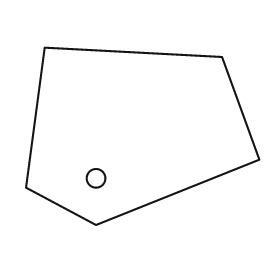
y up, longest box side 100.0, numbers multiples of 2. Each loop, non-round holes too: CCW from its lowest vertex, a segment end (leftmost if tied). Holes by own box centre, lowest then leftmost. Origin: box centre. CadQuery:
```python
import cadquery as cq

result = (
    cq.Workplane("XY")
    .moveTo(-20.0, -38.0)
    .lineTo(50.0, -10.0)
    .lineTo(34.0, 34.0)
    .lineTo(-42.0, 38.0)
    .lineTo(-50.0, -22.0)
    .close()
    .moveTo(-20.0, -18.0)
    .circle(4.0)
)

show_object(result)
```